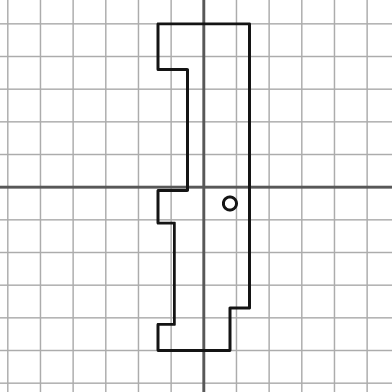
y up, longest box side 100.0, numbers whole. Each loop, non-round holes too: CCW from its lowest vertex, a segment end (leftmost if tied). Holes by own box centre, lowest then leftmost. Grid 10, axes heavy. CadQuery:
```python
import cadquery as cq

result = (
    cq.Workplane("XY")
    .moveTo(-14.0, -50.0)
    .lineTo(8.0, -50.0)
    .lineTo(8.0, -37.0)
    .lineTo(14.0, -37.0)
    .lineTo(14.0, 50.0)
    .lineTo(-14.0, 50.0)
    .lineTo(-14.0, 36.0)
    .lineTo(-5.0, 36.0)
    .lineTo(-5.0, -1.0)
    .lineTo(-14.0, -1.0)
    .lineTo(-14.0, -11.0)
    .lineTo(-9.0, -11.0)
    .lineTo(-9.0, -42.0)
    .lineTo(-14.0, -42.0)
    .close()
    .moveTo(8.0, -5.0)
    .circle(2.0)
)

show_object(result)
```